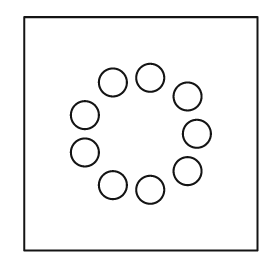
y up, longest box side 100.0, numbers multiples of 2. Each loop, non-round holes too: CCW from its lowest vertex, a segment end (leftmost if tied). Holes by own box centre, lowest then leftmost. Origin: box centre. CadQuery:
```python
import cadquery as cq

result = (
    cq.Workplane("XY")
    .moveTo(-50.0, -50.0)
    .lineTo(50.0, -50.0)
    .lineTo(50.0, 50.0)
    .lineTo(-50.0, 50.0)
    .close()
    .moveTo(4.0, -24.0)
    .circle(6.0)
    .moveTo(-12.0, -22.0)
    .circle(6.0)
    .moveTo(20.0, -16.0)
    .circle(6.0)
    .moveTo(-24.0, -8.0)
    .circle(6.0)
    .moveTo(24.0, 0.0)
    .circle(6.0)
    .moveTo(-24.0, 8.0)
    .circle(6.0)
    .moveTo(20.0, 16.0)
    .circle(6.0)
    .moveTo(-12.0, 22.0)
    .circle(6.0)
    .moveTo(4.0, 24.0)
    .circle(6.0)
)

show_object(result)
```